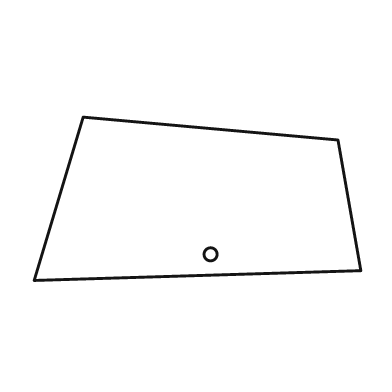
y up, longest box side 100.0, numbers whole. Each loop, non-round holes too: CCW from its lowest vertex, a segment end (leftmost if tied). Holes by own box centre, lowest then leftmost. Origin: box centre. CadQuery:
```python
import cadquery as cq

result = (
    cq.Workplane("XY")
    .moveTo(-50.0, -25.0)
    .lineTo(50.0, -22.0)
    .lineTo(43.0, 18.0)
    .lineTo(-35.0, 25.0)
    .close()
    .moveTo(4.0, -17.0)
    .circle(2.0)
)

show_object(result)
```